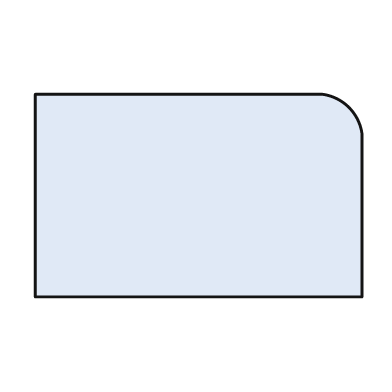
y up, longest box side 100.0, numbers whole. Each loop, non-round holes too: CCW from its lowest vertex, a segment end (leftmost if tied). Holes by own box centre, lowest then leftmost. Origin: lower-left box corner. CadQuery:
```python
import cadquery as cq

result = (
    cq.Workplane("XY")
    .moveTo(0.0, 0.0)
    .lineTo(100.0, 0.0)
    .lineTo(100.0, 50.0)
    .threePointArc((96.0, 58.0), (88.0, 62.0))
    .lineTo(0.0, 62.0)
    .close()
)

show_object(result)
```